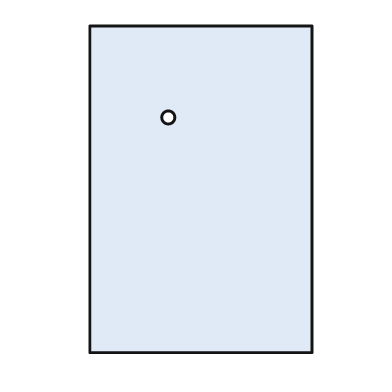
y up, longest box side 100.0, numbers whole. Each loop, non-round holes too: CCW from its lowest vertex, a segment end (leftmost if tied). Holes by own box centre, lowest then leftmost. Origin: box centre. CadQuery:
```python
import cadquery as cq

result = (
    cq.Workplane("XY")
    .moveTo(-34.0, -50.0)
    .lineTo(34.0, -50.0)
    .lineTo(34.0, 50.0)
    .lineTo(-34.0, 50.0)
    .close()
    .moveTo(-10.0, 22.0)
    .circle(2.0)
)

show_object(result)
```